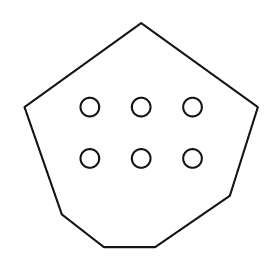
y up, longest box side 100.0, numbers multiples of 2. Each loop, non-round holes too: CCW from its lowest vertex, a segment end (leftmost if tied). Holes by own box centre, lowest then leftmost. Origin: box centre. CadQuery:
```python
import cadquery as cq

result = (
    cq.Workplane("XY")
    .moveTo(-16.0, -48.0)
    .lineTo(6.0, -48.0)
    .lineTo(38.0, -26.0)
    .lineTo(50.0, 12.0)
    .lineTo(0.0, 48.0)
    .lineTo(-50.0, 12.0)
    .lineTo(-34.0, -34.0)
    .close()
    .moveTo(-22.0, -10.0)
    .circle(4.0)
    .moveTo(0.0, -10.0)
    .circle(4.0)
    .moveTo(22.0, -10.0)
    .circle(4.0)
    .moveTo(-22.0, 12.0)
    .circle(4.0)
    .moveTo(0.0, 12.0)
    .circle(4.0)
    .moveTo(22.0, 12.0)
    .circle(4.0)
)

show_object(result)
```